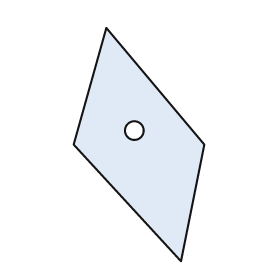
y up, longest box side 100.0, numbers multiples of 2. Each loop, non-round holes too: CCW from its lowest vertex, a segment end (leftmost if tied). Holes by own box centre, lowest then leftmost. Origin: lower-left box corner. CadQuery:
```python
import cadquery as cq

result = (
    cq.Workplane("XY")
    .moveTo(46.0, 0.0)
    .lineTo(56.0, 50.0)
    .lineTo(14.0, 100.0)
    .lineTo(0.0, 50.0)
    .close()
    .moveTo(26.0, 56.0)
    .circle(4.0)
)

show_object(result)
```